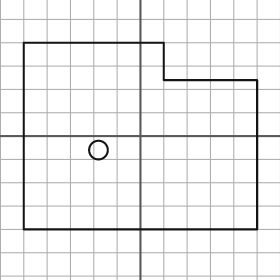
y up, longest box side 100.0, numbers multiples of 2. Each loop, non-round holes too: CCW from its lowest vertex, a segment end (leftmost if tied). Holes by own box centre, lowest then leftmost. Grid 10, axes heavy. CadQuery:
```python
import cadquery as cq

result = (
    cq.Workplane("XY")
    .moveTo(-50.0, -40.0)
    .lineTo(50.0, -40.0)
    .lineTo(50.0, 24.0)
    .lineTo(10.0, 24.0)
    .lineTo(10.0, 40.0)
    .lineTo(-50.0, 40.0)
    .close()
    .moveTo(-18.0, -6.0)
    .circle(4.0)
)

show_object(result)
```